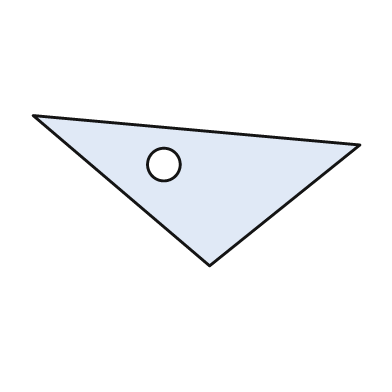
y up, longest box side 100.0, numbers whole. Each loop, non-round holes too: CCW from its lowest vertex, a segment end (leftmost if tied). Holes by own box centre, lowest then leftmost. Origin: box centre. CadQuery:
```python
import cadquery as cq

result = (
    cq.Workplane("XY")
    .moveTo(4.0, -23.0)
    .lineTo(50.0, 14.0)
    .lineTo(-50.0, 23.0)
    .close()
    .moveTo(-10.0, 8.0)
    .circle(5.0)
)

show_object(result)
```